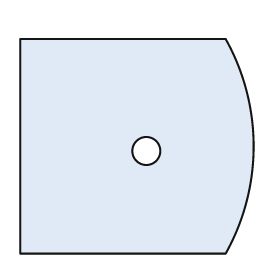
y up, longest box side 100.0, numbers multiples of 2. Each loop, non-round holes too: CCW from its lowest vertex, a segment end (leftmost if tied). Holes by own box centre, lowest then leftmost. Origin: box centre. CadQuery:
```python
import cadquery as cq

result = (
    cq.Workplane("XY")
    .moveTo(-50.0, -46.0)
    .lineTo(38.0, -46.0)
    .threePointArc((50.0, 0.0), (38.0, 46.0))
    .lineTo(-50.0, 46.0)
    .close()
    .moveTo(4.0, -2.0)
    .circle(6.0)
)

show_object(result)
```